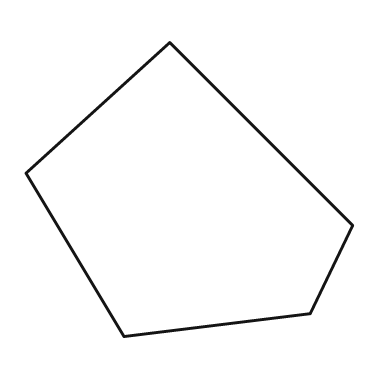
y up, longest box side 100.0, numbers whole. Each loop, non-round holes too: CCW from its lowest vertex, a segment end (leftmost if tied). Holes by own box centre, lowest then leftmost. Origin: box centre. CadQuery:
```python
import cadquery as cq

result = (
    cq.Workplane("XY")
    .moveTo(-20.0, -45.0)
    .lineTo(37.0, -38.0)
    .lineTo(50.0, -11.0)
    .lineTo(-6.0, 45.0)
    .lineTo(-50.0, 5.0)
    .close()
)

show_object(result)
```